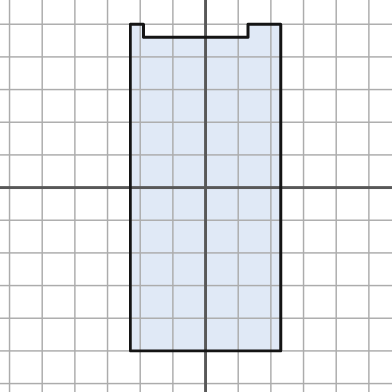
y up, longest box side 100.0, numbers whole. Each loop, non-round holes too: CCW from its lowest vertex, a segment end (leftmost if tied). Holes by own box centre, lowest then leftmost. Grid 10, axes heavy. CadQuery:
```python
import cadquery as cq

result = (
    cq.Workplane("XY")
    .moveTo(-23.0, -50.0)
    .lineTo(23.0, -50.0)
    .lineTo(23.0, 50.0)
    .lineTo(13.0, 50.0)
    .lineTo(13.0, 46.0)
    .lineTo(-19.0, 46.0)
    .lineTo(-19.0, 50.0)
    .lineTo(-23.0, 50.0)
    .close()
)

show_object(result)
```